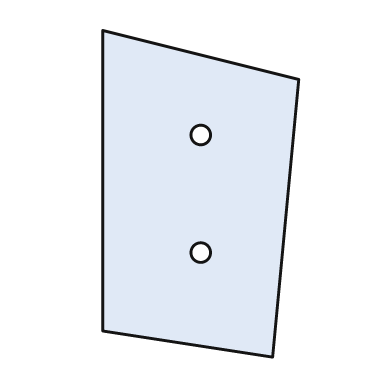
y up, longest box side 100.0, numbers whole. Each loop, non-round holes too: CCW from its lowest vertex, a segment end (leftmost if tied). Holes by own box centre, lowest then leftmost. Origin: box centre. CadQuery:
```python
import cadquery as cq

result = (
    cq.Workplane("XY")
    .moveTo(22.0, -50.0)
    .lineTo(30.0, 35.0)
    .lineTo(-30.0, 50.0)
    .lineTo(-30.0, -42.0)
    .close()
    .moveTo(0.0, -18.0)
    .circle(3.0)
    .moveTo(0.0, 18.0)
    .circle(3.0)
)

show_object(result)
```